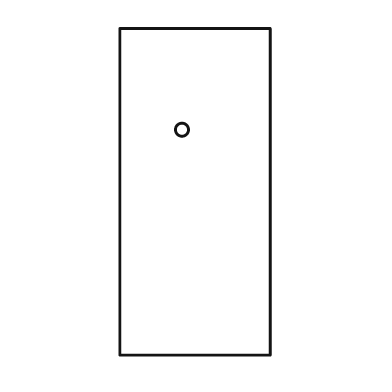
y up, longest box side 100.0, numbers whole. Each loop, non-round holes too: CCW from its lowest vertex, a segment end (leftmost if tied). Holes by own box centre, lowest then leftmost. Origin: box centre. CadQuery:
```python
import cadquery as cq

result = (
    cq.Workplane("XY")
    .moveTo(-23.0, -50.0)
    .lineTo(23.0, -50.0)
    .lineTo(23.0, 50.0)
    .lineTo(-23.0, 50.0)
    .close()
    .moveTo(-4.0, 19.0)
    .circle(2.0)
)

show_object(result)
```